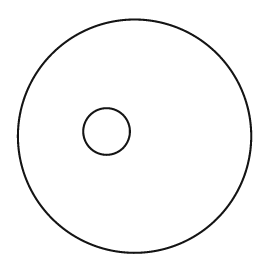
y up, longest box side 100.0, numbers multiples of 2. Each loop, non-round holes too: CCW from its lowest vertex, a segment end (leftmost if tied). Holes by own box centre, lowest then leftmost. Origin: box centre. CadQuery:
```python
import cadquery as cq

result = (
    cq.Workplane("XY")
    .moveTo(0.0, 0.0)
    .circle(50.0)
    .moveTo(-12.0, 2.0)
    .circle(10.0)
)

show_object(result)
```